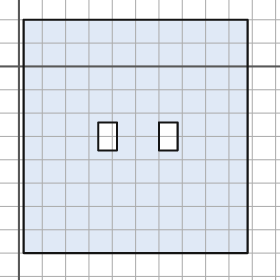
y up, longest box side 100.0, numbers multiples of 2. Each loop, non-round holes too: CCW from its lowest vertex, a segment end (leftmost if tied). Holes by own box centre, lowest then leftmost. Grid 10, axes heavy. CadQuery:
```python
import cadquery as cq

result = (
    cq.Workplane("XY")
    .moveTo(2.0, -80.0)
    .lineTo(98.0, -80.0)
    .lineTo(98.0, 20.0)
    .lineTo(2.0, 20.0)
    .close()
    .moveTo(34.0, -36.0)
    .lineTo(42.0, -36.0)
    .lineTo(42.0, -24.0)
    .lineTo(34.0, -24.0)
    .close()
    .moveTo(60.0, -36.0)
    .lineTo(68.0, -36.0)
    .lineTo(68.0, -24.0)
    .lineTo(60.0, -24.0)
    .close()
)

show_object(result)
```